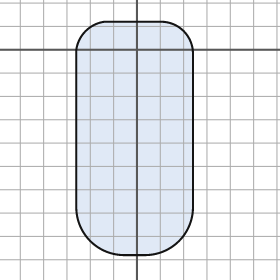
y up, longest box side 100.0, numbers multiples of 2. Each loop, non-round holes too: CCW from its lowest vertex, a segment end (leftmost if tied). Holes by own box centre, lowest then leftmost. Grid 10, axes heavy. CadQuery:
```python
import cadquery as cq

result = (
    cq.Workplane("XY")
    .moveTo(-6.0, -88.0)
    .lineTo(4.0, -88.0)
    .threePointArc((18.0, -82.0), (24.0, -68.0))
    .lineTo(24.0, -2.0)
    .threePointArc((20.0, 8.0), (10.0, 12.0))
    .lineTo(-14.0, 12.0)
    .threePointArc((-22.0, 8.0), (-26.0, 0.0))
    .lineTo(-26.0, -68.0)
    .threePointArc((-20.0, -82.0), (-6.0, -88.0))
    .close()
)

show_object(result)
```